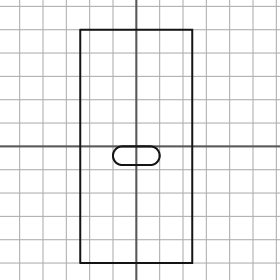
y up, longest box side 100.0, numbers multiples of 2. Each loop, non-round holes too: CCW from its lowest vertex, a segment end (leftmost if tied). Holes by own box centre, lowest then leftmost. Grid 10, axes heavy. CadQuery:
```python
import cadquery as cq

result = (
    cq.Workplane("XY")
    .moveTo(-24.0, -50.0)
    .lineTo(24.0, -50.0)
    .lineTo(24.0, 50.0)
    .lineTo(-24.0, 50.0)
    .close()
    .moveTo(-6.0, -8.0)
    .lineTo(6.0, -8.0)
    .threePointArc((10.0, -4.0), (6.0, 0.0))
    .lineTo(-6.0, 0.0)
    .threePointArc((-10.0, -4.0), (-6.0, -8.0))
    .close()
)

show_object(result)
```